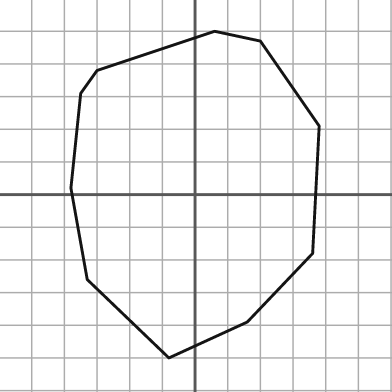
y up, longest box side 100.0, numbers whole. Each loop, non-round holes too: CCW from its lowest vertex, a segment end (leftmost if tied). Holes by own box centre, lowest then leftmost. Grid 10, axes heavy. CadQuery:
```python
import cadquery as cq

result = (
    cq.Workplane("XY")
    .moveTo(-8.0, -50.0)
    .lineTo(16.0, -39.0)
    .lineTo(36.0, -18.0)
    .lineTo(38.0, 21.0)
    .lineTo(20.0, 47.0)
    .lineTo(6.0, 50.0)
    .lineTo(-30.0, 38.0)
    .lineTo(-35.0, 31.0)
    .lineTo(-38.0, 2.0)
    .lineTo(-33.0, -26.0)
    .close()
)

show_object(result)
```